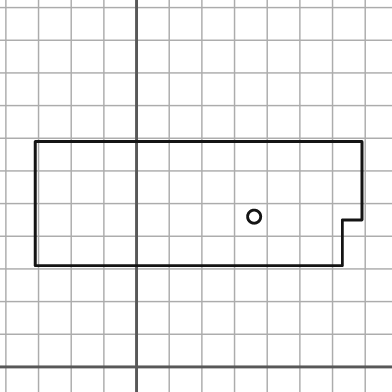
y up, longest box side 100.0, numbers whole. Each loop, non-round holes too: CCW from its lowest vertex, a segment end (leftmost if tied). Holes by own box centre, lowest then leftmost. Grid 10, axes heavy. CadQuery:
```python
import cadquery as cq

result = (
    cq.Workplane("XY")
    .moveTo(-31.0, 31.0)
    .lineTo(63.0, 31.0)
    .lineTo(63.0, 45.0)
    .lineTo(69.0, 45.0)
    .lineTo(69.0, 69.0)
    .lineTo(-31.0, 69.0)
    .close()
    .moveTo(36.0, 46.0)
    .circle(2.0)
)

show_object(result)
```